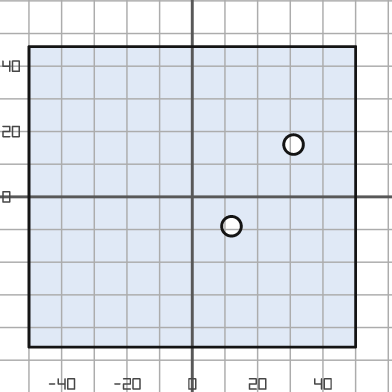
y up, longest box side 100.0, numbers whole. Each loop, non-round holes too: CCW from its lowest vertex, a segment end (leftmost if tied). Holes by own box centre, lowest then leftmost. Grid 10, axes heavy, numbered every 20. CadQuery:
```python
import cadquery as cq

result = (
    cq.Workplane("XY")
    .moveTo(-50.0, -46.0)
    .lineTo(50.0, -46.0)
    .lineTo(50.0, 46.0)
    .lineTo(-50.0, 46.0)
    .close()
    .moveTo(12.0, -9.0)
    .circle(3.0)
    .moveTo(31.0, 16.0)
    .circle(3.0)
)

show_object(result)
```